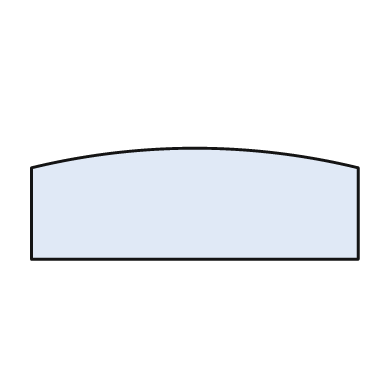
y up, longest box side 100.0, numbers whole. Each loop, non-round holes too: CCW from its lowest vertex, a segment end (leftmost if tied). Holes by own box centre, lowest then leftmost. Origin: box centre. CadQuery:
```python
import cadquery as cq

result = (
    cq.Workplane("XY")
    .moveTo(-50.0, -17.0)
    .lineTo(50.0, -17.0)
    .lineTo(50.0, 11.0)
    .threePointArc((0.0, 17.0), (-50.0, 11.0))
    .close()
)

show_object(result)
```